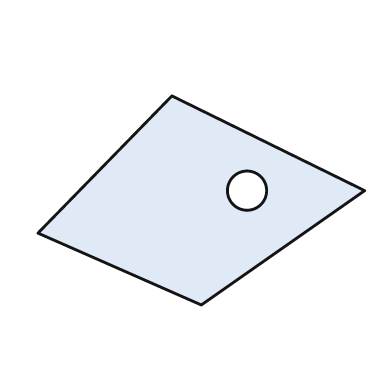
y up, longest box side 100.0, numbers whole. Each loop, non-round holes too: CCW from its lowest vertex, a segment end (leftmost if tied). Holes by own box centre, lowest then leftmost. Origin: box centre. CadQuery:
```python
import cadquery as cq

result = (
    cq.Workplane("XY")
    .moveTo(0.0, -32.0)
    .lineTo(50.0, 3.0)
    .lineTo(-9.0, 32.0)
    .lineTo(-50.0, -10.0)
    .close()
    .moveTo(14.0, 3.0)
    .circle(6.0)
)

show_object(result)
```